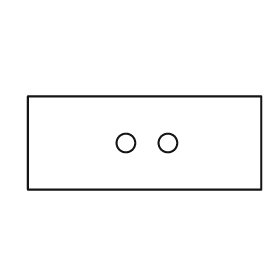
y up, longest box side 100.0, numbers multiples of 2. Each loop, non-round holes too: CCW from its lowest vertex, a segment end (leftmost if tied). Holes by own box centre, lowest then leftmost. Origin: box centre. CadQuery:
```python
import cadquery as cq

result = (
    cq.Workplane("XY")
    .moveTo(-50.0, -20.0)
    .lineTo(50.0, -20.0)
    .lineTo(50.0, 20.0)
    .lineTo(-50.0, 20.0)
    .close()
    .moveTo(-8.0, 0.0)
    .circle(4.0)
    .moveTo(10.0, 0.0)
    .circle(4.0)
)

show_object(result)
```